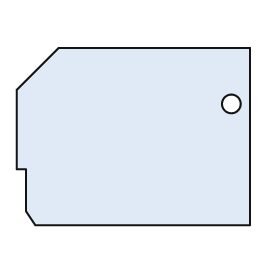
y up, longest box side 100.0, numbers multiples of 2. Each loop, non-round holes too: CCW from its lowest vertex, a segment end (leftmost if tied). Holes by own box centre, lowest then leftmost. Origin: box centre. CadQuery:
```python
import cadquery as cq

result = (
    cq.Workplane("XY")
    .moveTo(-42.0, -38.0)
    .lineTo(50.0, -38.0)
    .lineTo(50.0, 38.0)
    .lineTo(-32.0, 38.0)
    .lineTo(-50.0, 20.0)
    .lineTo(-50.0, -14.0)
    .lineTo(-46.0, -14.0)
    .lineTo(-46.0, -32.0)
    .close()
    .moveTo(42.0, 14.0)
    .circle(4.0)
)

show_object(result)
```